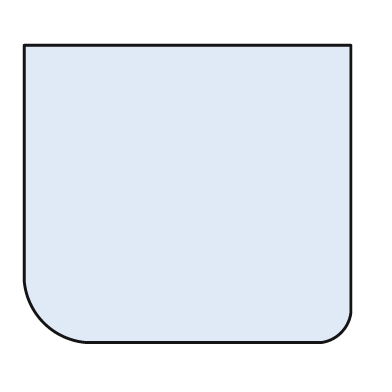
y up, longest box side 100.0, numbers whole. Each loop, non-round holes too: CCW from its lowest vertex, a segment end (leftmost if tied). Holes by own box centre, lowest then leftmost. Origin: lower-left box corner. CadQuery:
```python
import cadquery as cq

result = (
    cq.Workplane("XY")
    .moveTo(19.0, 0.0)
    .lineTo(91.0, 0.0)
    .threePointArc((97.0, 3.0), (100.0, 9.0))
    .lineTo(100.0, 91.0)
    .lineTo(0.0, 91.0)
    .lineTo(0.0, 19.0)
    .threePointArc((6.0, 6.0), (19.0, 0.0))
    .close()
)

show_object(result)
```